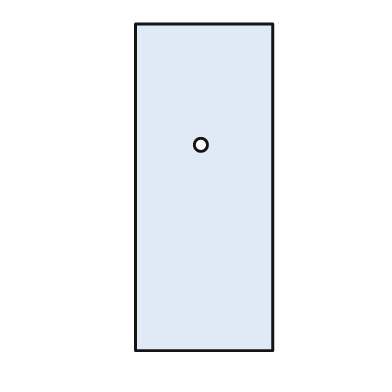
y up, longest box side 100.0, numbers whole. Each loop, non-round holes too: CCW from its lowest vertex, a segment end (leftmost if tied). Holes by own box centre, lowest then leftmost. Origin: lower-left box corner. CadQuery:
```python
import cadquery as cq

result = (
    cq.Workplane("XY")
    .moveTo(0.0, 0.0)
    .lineTo(42.0, 0.0)
    .lineTo(42.0, 100.0)
    .lineTo(0.0, 100.0)
    .close()
    .moveTo(20.0, 63.0)
    .circle(2.0)
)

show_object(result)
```